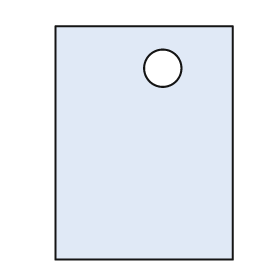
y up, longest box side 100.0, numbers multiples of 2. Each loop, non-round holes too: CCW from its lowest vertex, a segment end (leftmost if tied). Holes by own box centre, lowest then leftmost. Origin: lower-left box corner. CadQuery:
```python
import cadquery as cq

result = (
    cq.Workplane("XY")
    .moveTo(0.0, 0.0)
    .lineTo(76.0, 0.0)
    .lineTo(76.0, 100.0)
    .lineTo(0.0, 100.0)
    .close()
    .moveTo(46.0, 82.0)
    .circle(8.0)
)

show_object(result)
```